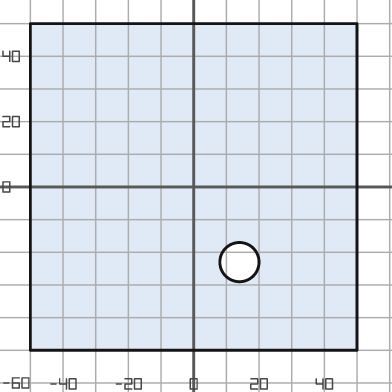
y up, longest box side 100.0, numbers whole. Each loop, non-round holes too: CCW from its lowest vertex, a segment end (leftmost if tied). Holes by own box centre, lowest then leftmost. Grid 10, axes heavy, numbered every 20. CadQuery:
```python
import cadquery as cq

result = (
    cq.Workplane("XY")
    .moveTo(-50.0, -50.0)
    .lineTo(50.0, -50.0)
    .lineTo(50.0, 50.0)
    .lineTo(-50.0, 50.0)
    .close()
    .moveTo(14.0, -23.0)
    .circle(6.0)
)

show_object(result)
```